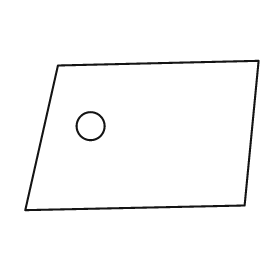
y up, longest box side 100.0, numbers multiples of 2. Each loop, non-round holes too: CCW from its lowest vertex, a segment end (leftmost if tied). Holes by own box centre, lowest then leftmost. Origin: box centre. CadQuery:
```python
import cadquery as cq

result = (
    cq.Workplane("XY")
    .moveTo(-50.0, -32.0)
    .lineTo(44.0, -30.0)
    .lineTo(50.0, 32.0)
    .lineTo(-36.0, 30.0)
    .close()
    .moveTo(-22.0, 4.0)
    .circle(6.0)
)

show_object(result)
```